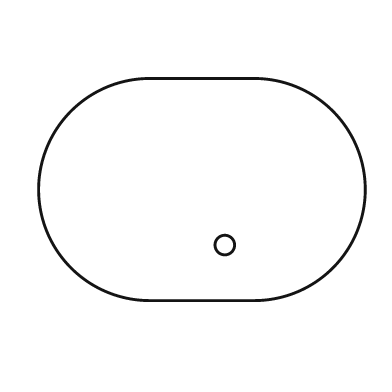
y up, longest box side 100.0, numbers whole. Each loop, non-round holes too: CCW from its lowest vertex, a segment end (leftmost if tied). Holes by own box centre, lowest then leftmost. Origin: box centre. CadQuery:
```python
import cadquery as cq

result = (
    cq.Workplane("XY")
    .moveTo(-16.0, -34.0)
    .lineTo(16.0, -34.0)
    .threePointArc((50.0, 0.0), (16.0, 34.0))
    .lineTo(-16.0, 34.0)
    .threePointArc((-50.0, 0.0), (-16.0, -34.0))
    .close()
    .moveTo(7.0, -17.0)
    .circle(3.0)
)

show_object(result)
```